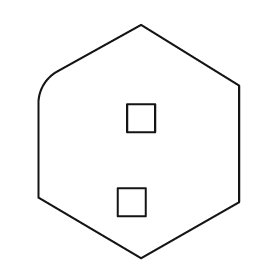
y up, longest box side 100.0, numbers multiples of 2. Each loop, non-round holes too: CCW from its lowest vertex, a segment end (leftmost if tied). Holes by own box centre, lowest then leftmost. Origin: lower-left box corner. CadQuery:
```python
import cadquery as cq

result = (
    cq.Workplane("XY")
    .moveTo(44.0, 0.0)
    .lineTo(86.0, 24.0)
    .lineTo(86.0, 74.0)
    .lineTo(44.0, 100.0)
    .lineTo(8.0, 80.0)
    .threePointArc((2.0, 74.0), (0.0, 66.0))
    .lineTo(0.0, 26.0)
    .close()
    .moveTo(34.0, 18.0)
    .lineTo(46.0, 18.0)
    .lineTo(46.0, 30.0)
    .lineTo(34.0, 30.0)
    .close()
    .moveTo(38.0, 54.0)
    .lineTo(50.0, 54.0)
    .lineTo(50.0, 66.0)
    .lineTo(38.0, 66.0)
    .close()
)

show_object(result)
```